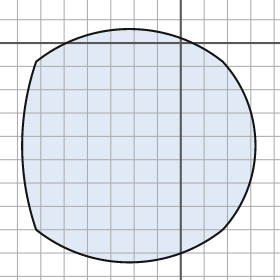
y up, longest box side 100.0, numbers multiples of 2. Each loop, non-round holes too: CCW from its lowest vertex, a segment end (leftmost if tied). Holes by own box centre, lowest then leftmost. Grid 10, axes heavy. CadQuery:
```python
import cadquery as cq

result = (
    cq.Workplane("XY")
    .moveTo(-62.0, -80.0)
    .threePointArc((-22.0, -94.0), (18.0, -80.0))
    .threePointArc((32.0, -44.0), (18.0, -8.0))
    .threePointArc((-22.0, 6.0), (-62.0, -8.0))
    .threePointArc((-68.0, -44.0), (-62.0, -80.0))
    .close()
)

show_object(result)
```